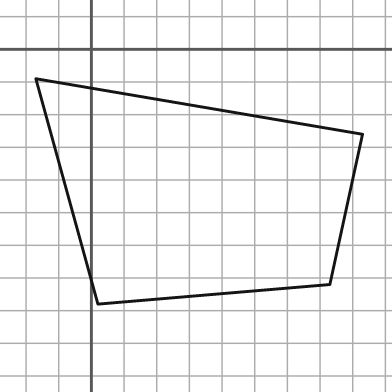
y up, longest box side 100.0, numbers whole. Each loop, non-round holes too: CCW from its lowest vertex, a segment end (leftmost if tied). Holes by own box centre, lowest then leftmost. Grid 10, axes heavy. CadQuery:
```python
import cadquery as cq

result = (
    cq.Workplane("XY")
    .moveTo(2.0, -78.0)
    .lineTo(73.0, -72.0)
    .lineTo(83.0, -26.0)
    .lineTo(-17.0, -9.0)
    .close()
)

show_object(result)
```